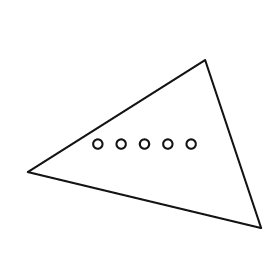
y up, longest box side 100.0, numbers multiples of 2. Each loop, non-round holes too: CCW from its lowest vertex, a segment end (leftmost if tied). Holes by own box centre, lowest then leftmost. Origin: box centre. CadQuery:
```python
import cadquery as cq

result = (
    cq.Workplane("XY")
    .moveTo(50.0, -36.0)
    .lineTo(26.0, 36.0)
    .lineTo(-50.0, -12.0)
    .close()
    .moveTo(-20.0, 0.0)
    .circle(2.0)
    .moveTo(-10.0, 0.0)
    .circle(2.0)
    .moveTo(0.0, 0.0)
    .circle(2.0)
    .moveTo(10.0, 0.0)
    .circle(2.0)
    .moveTo(20.0, 0.0)
    .circle(2.0)
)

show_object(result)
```